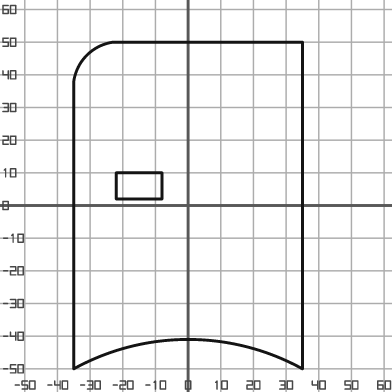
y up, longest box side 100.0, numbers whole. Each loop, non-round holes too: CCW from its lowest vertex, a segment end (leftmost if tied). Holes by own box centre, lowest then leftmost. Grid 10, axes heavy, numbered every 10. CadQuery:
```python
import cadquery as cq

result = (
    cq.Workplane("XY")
    .moveTo(-35.0, -50.0)
    .threePointArc((0.0, -41.0), (35.0, -50.0))
    .lineTo(35.0, 50.0)
    .lineTo(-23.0, 50.0)
    .threePointArc((-31.0, 46.0), (-35.0, 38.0))
    .close()
    .moveTo(-22.0, 2.0)
    .lineTo(-8.0, 2.0)
    .lineTo(-8.0, 10.0)
    .lineTo(-22.0, 10.0)
    .close()
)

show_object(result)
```